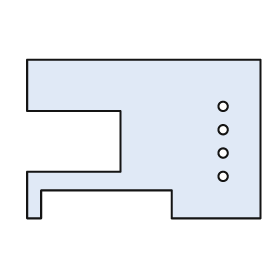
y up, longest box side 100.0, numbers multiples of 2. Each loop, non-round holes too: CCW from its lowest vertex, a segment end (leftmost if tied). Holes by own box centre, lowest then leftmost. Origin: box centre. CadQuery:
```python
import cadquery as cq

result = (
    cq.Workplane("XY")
    .moveTo(-50.0, -34.0)
    .lineTo(-44.0, -34.0)
    .lineTo(-44.0, -22.0)
    .lineTo(12.0, -22.0)
    .lineTo(12.0, -34.0)
    .lineTo(50.0, -34.0)
    .lineTo(50.0, 34.0)
    .lineTo(-50.0, 34.0)
    .lineTo(-50.0, 12.0)
    .lineTo(-10.0, 12.0)
    .lineTo(-10.0, -14.0)
    .lineTo(-50.0, -14.0)
    .close()
    .moveTo(34.0, -16.0)
    .circle(2.0)
    .moveTo(34.0, -6.0)
    .circle(2.0)
    .moveTo(34.0, 4.0)
    .circle(2.0)
    .moveTo(34.0, 14.0)
    .circle(2.0)
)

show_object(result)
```